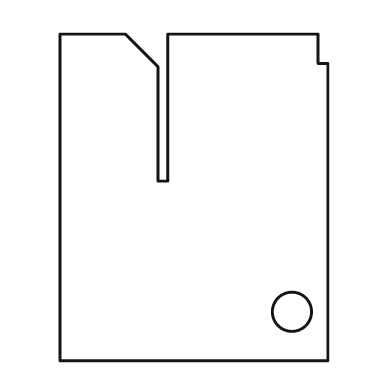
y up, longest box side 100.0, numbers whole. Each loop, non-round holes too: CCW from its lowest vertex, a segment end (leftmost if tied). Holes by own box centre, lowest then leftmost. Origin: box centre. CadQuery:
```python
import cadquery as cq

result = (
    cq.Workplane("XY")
    .moveTo(-41.0, -50.0)
    .lineTo(41.0, -50.0)
    .lineTo(41.0, 41.0)
    .lineTo(38.0, 41.0)
    .lineTo(38.0, 50.0)
    .lineTo(-8.0, 50.0)
    .lineTo(-8.0, 5.0)
    .lineTo(-11.0, 5.0)
    .lineTo(-11.0, 40.0)
    .lineTo(-21.0, 50.0)
    .lineTo(-41.0, 50.0)
    .close()
    .moveTo(30.0, -35.0)
    .circle(6.0)
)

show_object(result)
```